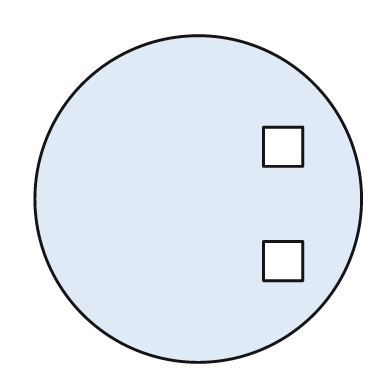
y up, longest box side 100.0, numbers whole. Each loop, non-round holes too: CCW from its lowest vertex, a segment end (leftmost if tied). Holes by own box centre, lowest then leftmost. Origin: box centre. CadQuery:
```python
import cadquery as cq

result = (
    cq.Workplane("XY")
    .moveTo(0.0, 0.0)
    .circle(50.0)
    .moveTo(20.0, -25.0)
    .lineTo(32.0, -25.0)
    .lineTo(32.0, -13.0)
    .lineTo(20.0, -13.0)
    .close()
    .moveTo(20.0, 10.0)
    .lineTo(32.0, 10.0)
    .lineTo(32.0, 22.0)
    .lineTo(20.0, 22.0)
    .close()
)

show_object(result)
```